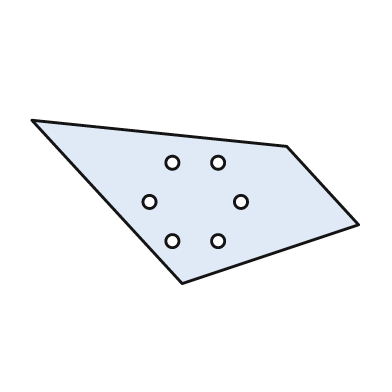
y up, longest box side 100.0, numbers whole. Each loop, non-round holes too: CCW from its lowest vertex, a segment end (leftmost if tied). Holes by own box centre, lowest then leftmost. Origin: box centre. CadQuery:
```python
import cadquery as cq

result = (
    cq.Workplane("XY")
    .moveTo(-4.0, -25.0)
    .lineTo(50.0, -7.0)
    .lineTo(28.0, 17.0)
    .lineTo(-50.0, 25.0)
    .close()
    .moveTo(-7.0, -12.0)
    .circle(2.0)
    .moveTo(7.0, -12.0)
    .circle(2.0)
    .moveTo(-14.0, 0.0)
    .circle(2.0)
    .moveTo(14.0, 0.0)
    .circle(2.0)
    .moveTo(-7.0, 12.0)
    .circle(2.0)
    .moveTo(7.0, 12.0)
    .circle(2.0)
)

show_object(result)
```